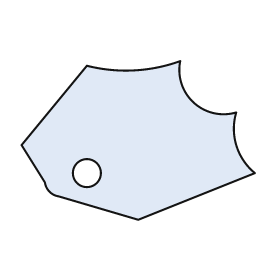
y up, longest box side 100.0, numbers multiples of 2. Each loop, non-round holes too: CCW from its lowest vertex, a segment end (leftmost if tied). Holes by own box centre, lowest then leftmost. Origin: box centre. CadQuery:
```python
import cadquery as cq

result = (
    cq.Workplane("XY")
    .moveTo(0.0, -34.0)
    .lineTo(50.0, -14.0)
    .threePointArc((42.0, -2.0), (42.0, 12.0))
    .threePointArc((24.0, 16.0), (18.0, 34.0))
    .threePointArc((-2.0, 30.0), (-22.0, 32.0))
    .lineTo(-50.0, -2.0)
    .lineTo(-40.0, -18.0)
    .threePointArc((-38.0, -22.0), (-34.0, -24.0))
    .close()
    .moveTo(-22.0, -14.0)
    .circle(6.0)
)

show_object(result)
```